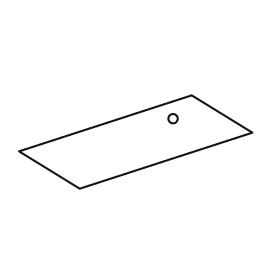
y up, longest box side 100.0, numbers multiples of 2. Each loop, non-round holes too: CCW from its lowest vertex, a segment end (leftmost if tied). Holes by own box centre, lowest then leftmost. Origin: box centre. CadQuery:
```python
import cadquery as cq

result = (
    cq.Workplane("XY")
    .moveTo(-24.0, -20.0)
    .lineTo(50.0, 4.0)
    .lineTo(24.0, 20.0)
    .lineTo(-50.0, -4.0)
    .close()
    .moveTo(16.0, 10.0)
    .circle(2.0)
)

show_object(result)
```